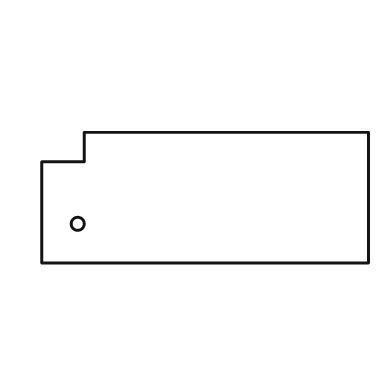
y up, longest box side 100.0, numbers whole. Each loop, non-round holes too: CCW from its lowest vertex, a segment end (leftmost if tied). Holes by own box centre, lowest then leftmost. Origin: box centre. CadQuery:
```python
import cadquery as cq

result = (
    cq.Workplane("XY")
    .moveTo(-50.0, -20.0)
    .lineTo(50.0, -20.0)
    .lineTo(50.0, 20.0)
    .lineTo(-37.0, 20.0)
    .lineTo(-37.0, 11.0)
    .lineTo(-50.0, 11.0)
    .close()
    .moveTo(-39.0, -8.0)
    .circle(2.0)
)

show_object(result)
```